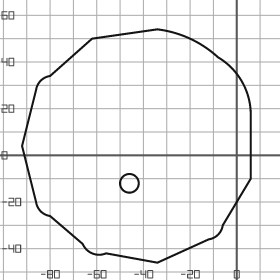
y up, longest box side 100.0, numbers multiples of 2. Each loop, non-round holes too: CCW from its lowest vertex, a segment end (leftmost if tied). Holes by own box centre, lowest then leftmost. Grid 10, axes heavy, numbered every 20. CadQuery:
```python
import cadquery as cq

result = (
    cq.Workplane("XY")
    .moveTo(-34.0, -46.0)
    .lineTo(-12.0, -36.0)
    .threePointArc((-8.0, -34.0), (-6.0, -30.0))
    .lineTo(6.0, -10.0)
    .lineTo(6.0, 18.0)
    .threePointArc((2.0, 32.0), (-8.0, 42.0))
    .threePointArc((-20.0, 50.0), (-34.0, 54.0))
    .lineTo(-62.0, 50.0)
    .lineTo(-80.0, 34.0)
    .threePointArc((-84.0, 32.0), (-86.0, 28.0))
    .lineTo(-92.0, 4.0)
    .lineTo(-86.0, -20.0)
    .threePointArc((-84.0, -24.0), (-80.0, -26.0))
    .lineTo(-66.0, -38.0)
    .threePointArc((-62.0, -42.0), (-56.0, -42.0))
    .close()
    .moveTo(-46.0, -12.0)
    .circle(4.0)
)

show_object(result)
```